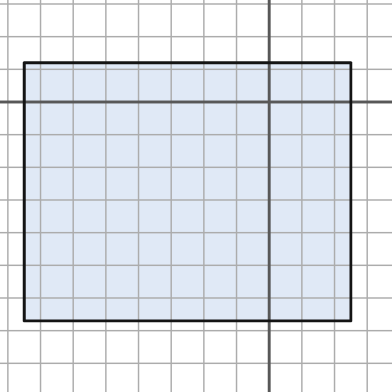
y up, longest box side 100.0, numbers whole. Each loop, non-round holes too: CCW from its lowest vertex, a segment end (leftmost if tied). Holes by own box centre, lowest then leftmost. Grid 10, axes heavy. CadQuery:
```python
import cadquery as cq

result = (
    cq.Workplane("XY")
    .moveTo(-75.0, -67.0)
    .lineTo(25.0, -67.0)
    .lineTo(25.0, 12.0)
    .lineTo(-75.0, 12.0)
    .close()
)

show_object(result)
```